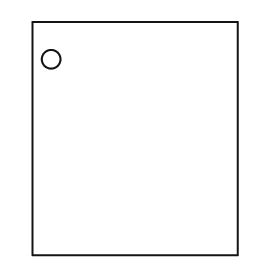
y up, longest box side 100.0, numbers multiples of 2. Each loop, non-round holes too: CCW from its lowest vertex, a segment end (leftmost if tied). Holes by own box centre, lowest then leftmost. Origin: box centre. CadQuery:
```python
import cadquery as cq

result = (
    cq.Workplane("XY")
    .moveTo(-44.0, -50.0)
    .lineTo(44.0, -50.0)
    .lineTo(44.0, 50.0)
    .lineTo(-44.0, 50.0)
    .close()
    .moveTo(-36.0, 34.0)
    .circle(4.0)
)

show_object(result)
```